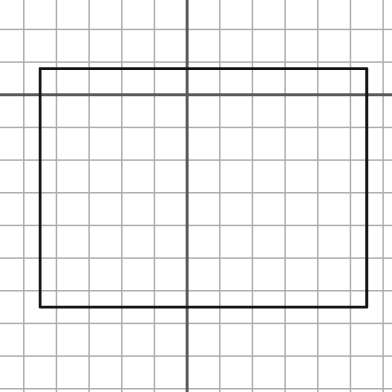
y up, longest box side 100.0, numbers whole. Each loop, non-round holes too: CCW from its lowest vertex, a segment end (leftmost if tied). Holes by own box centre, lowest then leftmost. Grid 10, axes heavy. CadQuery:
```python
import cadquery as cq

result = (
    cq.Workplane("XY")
    .moveTo(-45.0, -65.0)
    .lineTo(55.0, -65.0)
    .lineTo(55.0, 8.0)
    .lineTo(-45.0, 8.0)
    .close()
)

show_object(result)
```